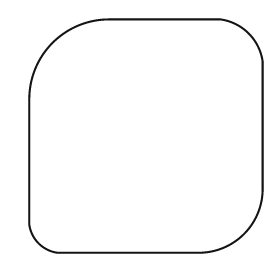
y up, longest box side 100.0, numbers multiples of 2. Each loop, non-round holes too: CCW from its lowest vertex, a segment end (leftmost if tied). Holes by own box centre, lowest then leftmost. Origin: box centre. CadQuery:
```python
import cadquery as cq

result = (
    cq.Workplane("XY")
    .moveTo(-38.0, -50.0)
    .lineTo(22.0, -50.0)
    .threePointArc((42.0, -42.0), (50.0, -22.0))
    .lineTo(50.0, 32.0)
    .threePointArc((44.0, 44.0), (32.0, 50.0))
    .lineTo(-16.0, 50.0)
    .threePointArc((-40.0, 40.0), (-50.0, 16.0))
    .lineTo(-50.0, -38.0)
    .threePointArc((-46.0, -46.0), (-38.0, -50.0))
    .close()
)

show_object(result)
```